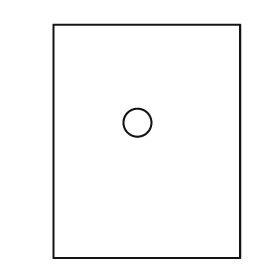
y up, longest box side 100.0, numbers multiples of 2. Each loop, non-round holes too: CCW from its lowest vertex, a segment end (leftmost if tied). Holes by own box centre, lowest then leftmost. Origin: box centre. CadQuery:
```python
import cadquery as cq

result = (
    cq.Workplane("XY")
    .moveTo(-40.0, -50.0)
    .lineTo(40.0, -50.0)
    .lineTo(40.0, 50.0)
    .lineTo(-40.0, 50.0)
    .close()
    .moveTo(-4.0, 8.0)
    .circle(6.0)
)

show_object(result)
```